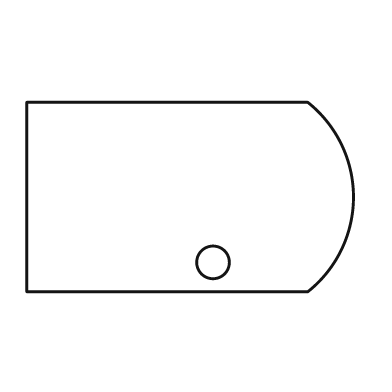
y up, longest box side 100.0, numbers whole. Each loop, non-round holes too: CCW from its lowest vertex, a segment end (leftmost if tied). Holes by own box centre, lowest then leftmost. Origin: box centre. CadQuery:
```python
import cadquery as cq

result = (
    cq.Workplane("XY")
    .moveTo(-50.0, -29.0)
    .lineTo(36.0, -29.0)
    .threePointArc((50.0, 0.0), (36.0, 29.0))
    .lineTo(-50.0, 29.0)
    .close()
    .moveTo(7.0, -20.0)
    .circle(5.0)
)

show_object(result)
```